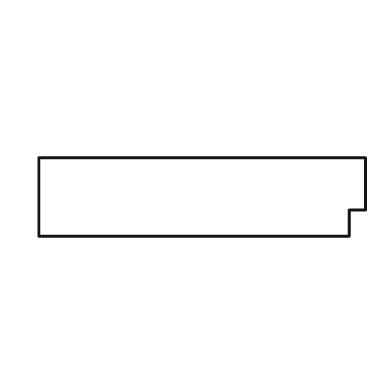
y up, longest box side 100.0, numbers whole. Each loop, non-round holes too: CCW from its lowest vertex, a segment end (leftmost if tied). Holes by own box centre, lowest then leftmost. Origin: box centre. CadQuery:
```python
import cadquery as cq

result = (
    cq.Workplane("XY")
    .moveTo(-50.0, -12.0)
    .lineTo(45.0, -12.0)
    .lineTo(45.0, -4.0)
    .lineTo(50.0, -4.0)
    .lineTo(50.0, 12.0)
    .lineTo(-50.0, 12.0)
    .close()
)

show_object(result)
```